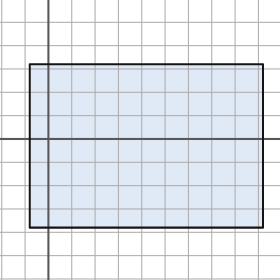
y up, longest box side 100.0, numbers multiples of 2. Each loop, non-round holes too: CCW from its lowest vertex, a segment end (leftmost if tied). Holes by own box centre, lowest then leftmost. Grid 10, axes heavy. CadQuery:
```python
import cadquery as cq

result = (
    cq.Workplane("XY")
    .moveTo(-8.0, -38.0)
    .lineTo(92.0, -38.0)
    .lineTo(92.0, 32.0)
    .lineTo(-8.0, 32.0)
    .close()
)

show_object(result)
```